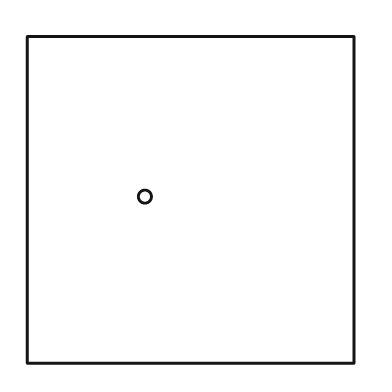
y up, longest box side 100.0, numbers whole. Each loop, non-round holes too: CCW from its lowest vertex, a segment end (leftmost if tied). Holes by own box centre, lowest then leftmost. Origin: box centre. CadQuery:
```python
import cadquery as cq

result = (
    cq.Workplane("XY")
    .moveTo(-50.0, -50.0)
    .lineTo(50.0, -50.0)
    .lineTo(50.0, 50.0)
    .lineTo(-50.0, 50.0)
    .close()
    .moveTo(-14.0, 1.0)
    .circle(2.0)
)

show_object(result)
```